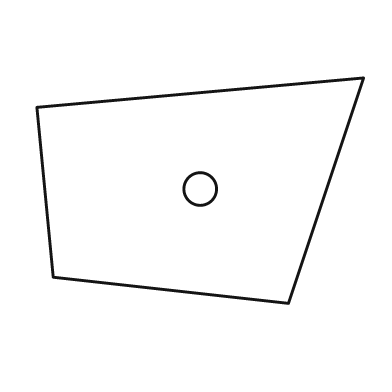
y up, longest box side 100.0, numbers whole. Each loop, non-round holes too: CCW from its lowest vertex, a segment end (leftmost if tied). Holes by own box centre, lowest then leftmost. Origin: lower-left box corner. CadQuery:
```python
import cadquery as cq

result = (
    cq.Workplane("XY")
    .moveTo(77.0, 0.0)
    .lineTo(100.0, 69.0)
    .lineTo(0.0, 60.0)
    .lineTo(5.0, 8.0)
    .close()
    .moveTo(50.0, 35.0)
    .circle(5.0)
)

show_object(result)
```